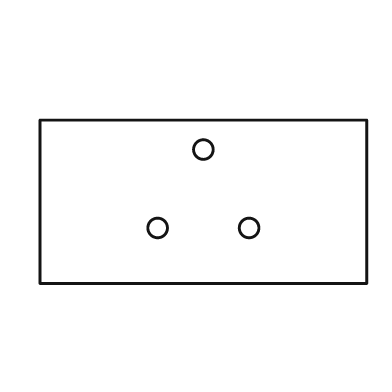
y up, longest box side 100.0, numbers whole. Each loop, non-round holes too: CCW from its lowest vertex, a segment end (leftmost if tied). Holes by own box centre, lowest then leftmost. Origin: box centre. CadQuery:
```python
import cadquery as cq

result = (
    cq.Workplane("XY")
    .moveTo(-50.0, -25.0)
    .lineTo(50.0, -25.0)
    .lineTo(50.0, 25.0)
    .lineTo(-50.0, 25.0)
    .close()
    .moveTo(-14.0, -8.0)
    .circle(3.0)
    .moveTo(14.0, -8.0)
    .circle(3.0)
    .moveTo(0.0, 16.0)
    .circle(3.0)
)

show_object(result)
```